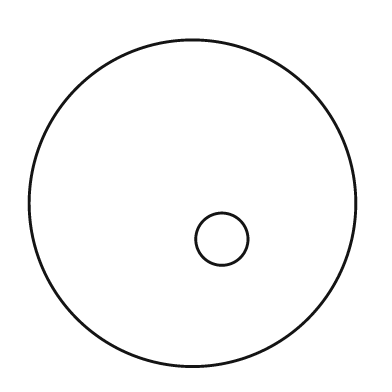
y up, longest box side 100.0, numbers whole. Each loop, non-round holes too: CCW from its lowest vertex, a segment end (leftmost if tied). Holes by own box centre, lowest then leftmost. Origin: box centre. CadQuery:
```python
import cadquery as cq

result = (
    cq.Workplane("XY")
    .moveTo(0.0, 0.0)
    .circle(50.0)
    .moveTo(9.0, -11.0)
    .circle(8.0)
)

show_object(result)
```